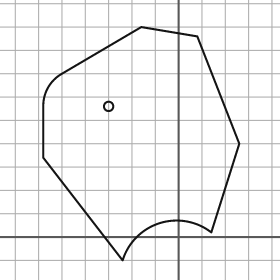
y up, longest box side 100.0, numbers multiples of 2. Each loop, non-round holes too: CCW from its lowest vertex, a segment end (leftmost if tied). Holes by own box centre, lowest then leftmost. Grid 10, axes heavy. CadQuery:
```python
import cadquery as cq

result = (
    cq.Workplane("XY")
    .moveTo(-24.0, -10.0)
    .threePointArc((-8.0, 6.0), (14.0, 2.0))
    .lineTo(26.0, 40.0)
    .lineTo(8.0, 86.0)
    .lineTo(-16.0, 90.0)
    .lineTo(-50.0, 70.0)
    .threePointArc((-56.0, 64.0), (-58.0, 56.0))
    .lineTo(-58.0, 34.0)
    .close()
    .moveTo(-30.0, 56.0)
    .circle(2.0)
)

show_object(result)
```